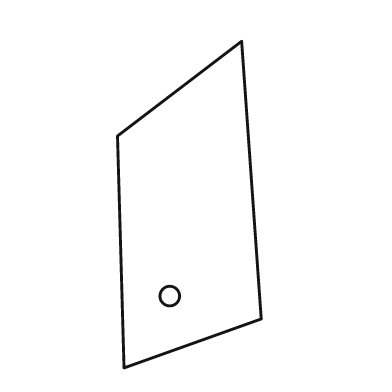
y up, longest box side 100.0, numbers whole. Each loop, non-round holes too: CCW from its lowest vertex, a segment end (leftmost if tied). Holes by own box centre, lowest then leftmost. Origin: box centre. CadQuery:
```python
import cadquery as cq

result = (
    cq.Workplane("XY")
    .moveTo(-20.0, -50.0)
    .lineTo(22.0, -35.0)
    .lineTo(16.0, 50.0)
    .lineTo(-22.0, 21.0)
    .close()
    .moveTo(-6.0, -28.0)
    .circle(3.0)
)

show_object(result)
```